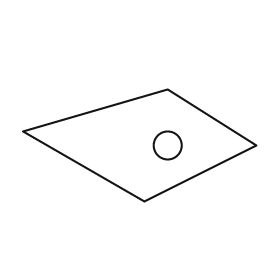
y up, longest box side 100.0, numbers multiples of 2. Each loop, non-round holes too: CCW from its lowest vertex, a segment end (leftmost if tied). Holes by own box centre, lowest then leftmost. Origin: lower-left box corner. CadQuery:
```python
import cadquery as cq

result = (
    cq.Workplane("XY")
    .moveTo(52.0, 0.0)
    .lineTo(100.0, 24.0)
    .lineTo(62.0, 48.0)
    .lineTo(0.0, 30.0)
    .close()
    .moveTo(62.0, 24.0)
    .circle(6.0)
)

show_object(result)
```